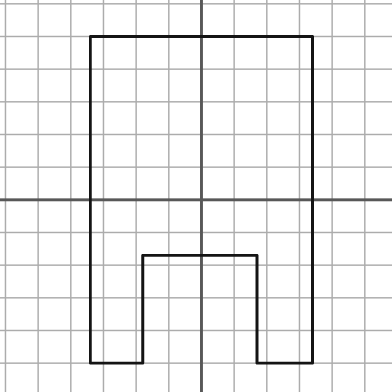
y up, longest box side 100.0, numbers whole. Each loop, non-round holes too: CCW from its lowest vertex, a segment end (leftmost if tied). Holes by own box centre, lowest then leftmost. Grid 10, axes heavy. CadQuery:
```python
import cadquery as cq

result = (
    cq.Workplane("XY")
    .moveTo(-34.0, -50.0)
    .lineTo(-18.0, -50.0)
    .lineTo(-18.0, -17.0)
    .lineTo(17.0, -17.0)
    .lineTo(17.0, -50.0)
    .lineTo(34.0, -50.0)
    .lineTo(34.0, 50.0)
    .lineTo(-34.0, 50.0)
    .close()
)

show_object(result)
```